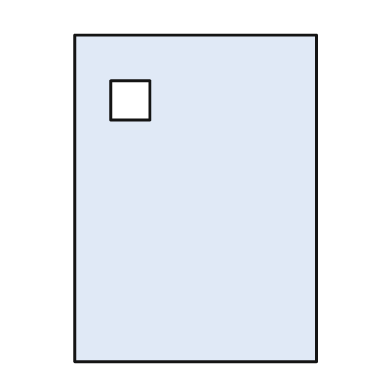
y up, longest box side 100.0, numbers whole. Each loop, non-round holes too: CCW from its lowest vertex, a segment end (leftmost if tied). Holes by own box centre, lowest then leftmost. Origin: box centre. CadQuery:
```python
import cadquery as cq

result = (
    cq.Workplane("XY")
    .moveTo(-37.0, -50.0)
    .lineTo(37.0, -50.0)
    .lineTo(37.0, 50.0)
    .lineTo(-37.0, 50.0)
    .close()
    .moveTo(-26.0, 24.0)
    .lineTo(-14.0, 24.0)
    .lineTo(-14.0, 36.0)
    .lineTo(-26.0, 36.0)
    .close()
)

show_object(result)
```